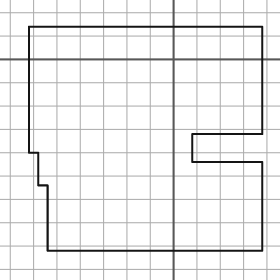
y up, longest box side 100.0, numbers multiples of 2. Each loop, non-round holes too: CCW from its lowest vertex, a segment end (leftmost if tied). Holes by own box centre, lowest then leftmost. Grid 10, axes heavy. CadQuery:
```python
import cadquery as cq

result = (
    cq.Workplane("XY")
    .moveTo(-54.0, -82.0)
    .lineTo(38.0, -82.0)
    .lineTo(38.0, -44.0)
    .lineTo(8.0, -44.0)
    .lineTo(8.0, -32.0)
    .lineTo(38.0, -32.0)
    .lineTo(38.0, 14.0)
    .lineTo(-62.0, 14.0)
    .lineTo(-62.0, -40.0)
    .lineTo(-58.0, -40.0)
    .lineTo(-58.0, -54.0)
    .lineTo(-54.0, -54.0)
    .close()
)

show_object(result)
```